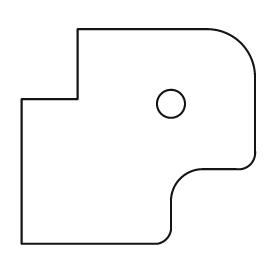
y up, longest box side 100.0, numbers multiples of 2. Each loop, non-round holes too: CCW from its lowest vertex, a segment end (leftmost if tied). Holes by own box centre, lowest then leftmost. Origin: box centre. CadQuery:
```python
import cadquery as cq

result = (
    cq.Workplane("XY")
    .moveTo(-50.0, -46.0)
    .lineTo(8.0, -46.0)
    .threePointArc((12.0, -44.0), (14.0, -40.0))
    .lineTo(14.0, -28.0)
    .threePointArc((18.0, -18.0), (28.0, -14.0))
    .lineTo(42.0, -14.0)
    .threePointArc((48.0, -12.0), (50.0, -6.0))
    .lineTo(50.0, 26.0)
    .threePointArc((44.0, 40.0), (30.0, 46.0))
    .lineTo(-26.0, 46.0)
    .lineTo(-26.0, 16.0)
    .lineTo(-50.0, 16.0)
    .close()
    .moveTo(14.0, 14.0)
    .circle(6.0)
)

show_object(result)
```